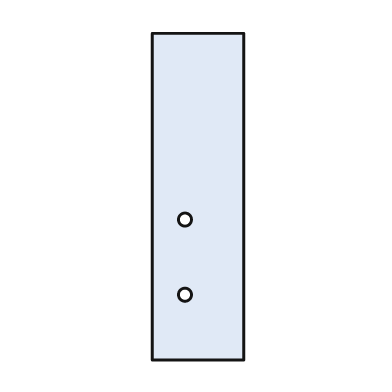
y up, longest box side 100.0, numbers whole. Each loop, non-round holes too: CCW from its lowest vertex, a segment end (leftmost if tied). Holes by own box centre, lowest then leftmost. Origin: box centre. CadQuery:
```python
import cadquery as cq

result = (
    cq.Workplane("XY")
    .moveTo(-14.0, -50.0)
    .lineTo(14.0, -50.0)
    .lineTo(14.0, 50.0)
    .lineTo(-14.0, 50.0)
    .close()
    .moveTo(-4.0, -30.0)
    .circle(2.0)
    .moveTo(-4.0, -7.0)
    .circle(2.0)
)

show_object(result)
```